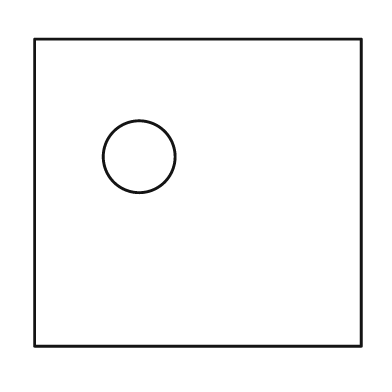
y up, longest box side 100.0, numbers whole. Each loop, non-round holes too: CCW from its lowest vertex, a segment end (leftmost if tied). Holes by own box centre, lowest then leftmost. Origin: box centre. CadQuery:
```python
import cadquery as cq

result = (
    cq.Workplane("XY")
    .moveTo(-50.0, -47.0)
    .lineTo(50.0, -47.0)
    .lineTo(50.0, 47.0)
    .lineTo(-50.0, 47.0)
    .close()
    .moveTo(-18.0, 11.0)
    .circle(11.0)
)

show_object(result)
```